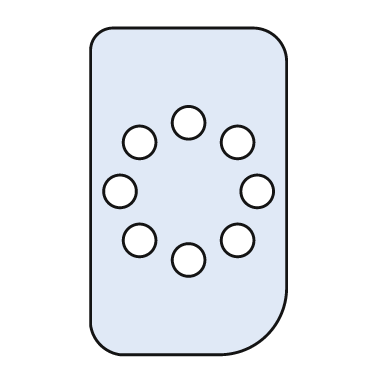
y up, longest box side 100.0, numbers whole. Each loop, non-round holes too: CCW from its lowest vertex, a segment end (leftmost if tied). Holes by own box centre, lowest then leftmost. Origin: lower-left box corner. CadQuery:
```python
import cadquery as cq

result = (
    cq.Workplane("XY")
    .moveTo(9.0, 0.0)
    .lineTo(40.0, 0.0)
    .threePointArc((54.0, 6.0), (60.0, 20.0))
    .lineTo(60.0, 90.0)
    .threePointArc((57.0, 97.0), (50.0, 100.0))
    .lineTo(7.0, 100.0)
    .threePointArc((2.0, 98.0), (0.0, 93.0))
    .lineTo(0.0, 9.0)
    .threePointArc((3.0, 3.0), (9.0, 0.0))
    .close()
    .moveTo(30.0, 29.0)
    .circle(5.0)
    .moveTo(15.0, 35.0)
    .circle(5.0)
    .moveTo(45.0, 35.0)
    .circle(5.0)
    .moveTo(9.0, 50.0)
    .circle(5.0)
    .moveTo(51.0, 50.0)
    .circle(5.0)
    .moveTo(15.0, 65.0)
    .circle(5.0)
    .moveTo(45.0, 65.0)
    .circle(5.0)
    .moveTo(30.0, 71.0)
    .circle(5.0)
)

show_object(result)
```